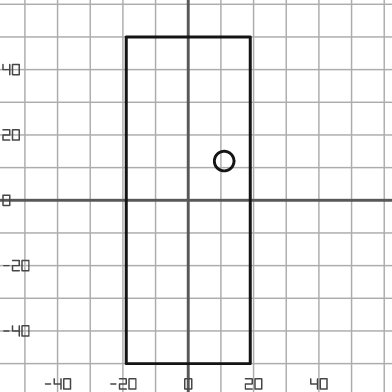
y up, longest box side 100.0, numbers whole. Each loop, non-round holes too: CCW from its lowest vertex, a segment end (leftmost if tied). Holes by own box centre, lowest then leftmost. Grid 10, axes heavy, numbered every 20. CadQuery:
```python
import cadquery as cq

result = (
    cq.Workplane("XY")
    .moveTo(-19.0, -50.0)
    .lineTo(19.0, -50.0)
    .lineTo(19.0, 50.0)
    .lineTo(-19.0, 50.0)
    .close()
    .moveTo(11.0, 12.0)
    .circle(3.0)
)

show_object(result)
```